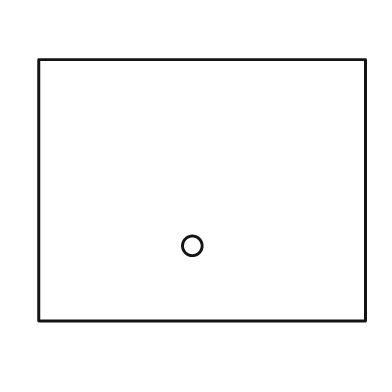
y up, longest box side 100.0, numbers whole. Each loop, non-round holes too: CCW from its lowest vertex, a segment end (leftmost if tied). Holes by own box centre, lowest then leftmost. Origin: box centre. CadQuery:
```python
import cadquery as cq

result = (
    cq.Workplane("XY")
    .moveTo(-50.0, -40.0)
    .lineTo(50.0, -40.0)
    .lineTo(50.0, 40.0)
    .lineTo(-50.0, 40.0)
    .close()
    .moveTo(-3.0, -17.0)
    .circle(3.0)
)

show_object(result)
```